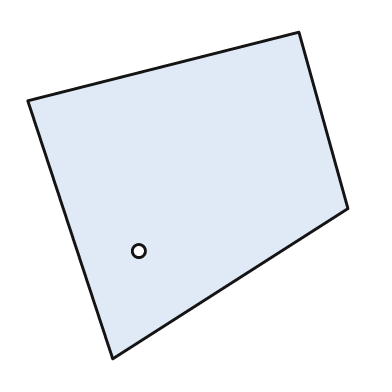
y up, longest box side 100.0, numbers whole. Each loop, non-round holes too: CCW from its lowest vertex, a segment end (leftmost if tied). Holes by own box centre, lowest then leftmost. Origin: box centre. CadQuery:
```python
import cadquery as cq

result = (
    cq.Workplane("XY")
    .moveTo(-23.0, -50.0)
    .lineTo(49.0, -4.0)
    .lineTo(34.0, 50.0)
    .lineTo(-49.0, 29.0)
    .close()
    .moveTo(-15.0, -17.0)
    .circle(2.0)
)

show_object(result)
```